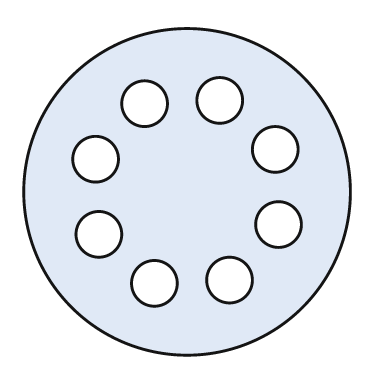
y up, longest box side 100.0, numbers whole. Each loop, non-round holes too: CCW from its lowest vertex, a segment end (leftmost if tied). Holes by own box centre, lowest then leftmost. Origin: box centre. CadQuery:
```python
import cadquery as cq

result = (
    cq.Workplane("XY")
    .moveTo(0.0, 0.0)
    .circle(50.0)
    .moveTo(-10.0, -28.0)
    .circle(7.0)
    .moveTo(13.0, -27.0)
    .circle(7.0)
    .moveTo(-27.0, -13.0)
    .circle(7.0)
    .moveTo(28.0, -10.0)
    .circle(7.0)
    .moveTo(-28.0, 10.0)
    .circle(7.0)
    .moveTo(27.0, 13.0)
    .circle(7.0)
    .moveTo(-13.0, 27.0)
    .circle(7.0)
    .moveTo(10.0, 28.0)
    .circle(7.0)
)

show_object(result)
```